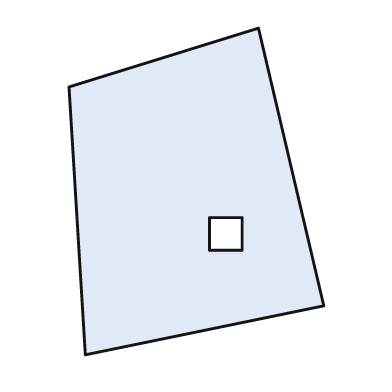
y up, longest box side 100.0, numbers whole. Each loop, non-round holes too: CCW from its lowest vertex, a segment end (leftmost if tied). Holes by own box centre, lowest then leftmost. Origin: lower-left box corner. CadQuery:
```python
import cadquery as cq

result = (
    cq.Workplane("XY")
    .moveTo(5.0, 0.0)
    .lineTo(78.0, 15.0)
    .lineTo(58.0, 100.0)
    .lineTo(0.0, 82.0)
    .close()
    .moveTo(43.0, 32.0)
    .lineTo(53.0, 32.0)
    .lineTo(53.0, 42.0)
    .lineTo(43.0, 42.0)
    .close()
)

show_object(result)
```